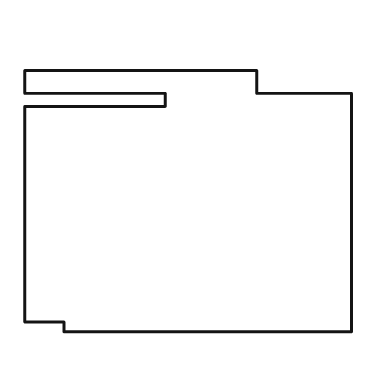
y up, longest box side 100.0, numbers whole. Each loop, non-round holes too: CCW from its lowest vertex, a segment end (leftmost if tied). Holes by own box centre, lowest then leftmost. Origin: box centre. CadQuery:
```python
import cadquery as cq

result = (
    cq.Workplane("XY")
    .moveTo(-38.0, -40.0)
    .lineTo(50.0, -40.0)
    .lineTo(50.0, 33.0)
    .lineTo(21.0, 33.0)
    .lineTo(21.0, 40.0)
    .lineTo(-50.0, 40.0)
    .lineTo(-50.0, 33.0)
    .lineTo(-7.0, 33.0)
    .lineTo(-7.0, 29.0)
    .lineTo(-50.0, 29.0)
    .lineTo(-50.0, -37.0)
    .lineTo(-38.0, -37.0)
    .close()
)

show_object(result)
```